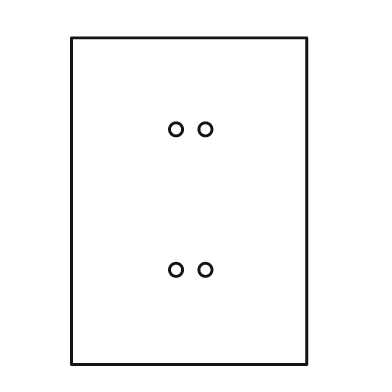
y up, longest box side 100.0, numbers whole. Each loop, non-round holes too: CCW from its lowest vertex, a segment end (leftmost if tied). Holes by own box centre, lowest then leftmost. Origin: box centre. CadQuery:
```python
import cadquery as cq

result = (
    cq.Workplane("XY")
    .moveTo(-36.0, -50.0)
    .lineTo(36.0, -50.0)
    .lineTo(36.0, 50.0)
    .lineTo(-36.0, 50.0)
    .close()
    .moveTo(-4.0, -21.0)
    .circle(2.0)
    .moveTo(5.0, -21.0)
    .circle(2.0)
    .moveTo(-4.0, 22.0)
    .circle(2.0)
    .moveTo(5.0, 22.0)
    .circle(2.0)
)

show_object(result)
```